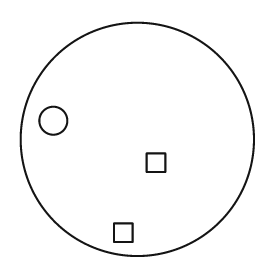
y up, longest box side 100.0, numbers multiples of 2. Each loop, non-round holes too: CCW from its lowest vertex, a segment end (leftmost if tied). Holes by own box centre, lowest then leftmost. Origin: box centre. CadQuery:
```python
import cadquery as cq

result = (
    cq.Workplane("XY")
    .moveTo(0.0, 0.0)
    .circle(50.0)
    .moveTo(-10.0, -44.0)
    .lineTo(-2.0, -44.0)
    .lineTo(-2.0, -36.0)
    .lineTo(-10.0, -36.0)
    .close()
    .moveTo(4.0, -14.0)
    .lineTo(12.0, -14.0)
    .lineTo(12.0, -6.0)
    .lineTo(4.0, -6.0)
    .close()
    .moveTo(-36.0, 8.0)
    .circle(6.0)
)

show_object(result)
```